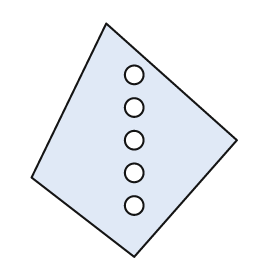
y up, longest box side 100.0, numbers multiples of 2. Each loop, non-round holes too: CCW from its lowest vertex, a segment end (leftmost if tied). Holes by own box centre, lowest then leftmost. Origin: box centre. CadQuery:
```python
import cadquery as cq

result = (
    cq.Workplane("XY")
    .moveTo(0.0, -50.0)
    .lineTo(44.0, 0.0)
    .lineTo(-12.0, 50.0)
    .lineTo(-44.0, -16.0)
    .close()
    .moveTo(0.0, -28.0)
    .circle(4.0)
    .moveTo(0.0, -14.0)
    .circle(4.0)
    .moveTo(0.0, 0.0)
    .circle(4.0)
    .moveTo(0.0, 14.0)
    .circle(4.0)
    .moveTo(0.0, 28.0)
    .circle(4.0)
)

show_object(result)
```